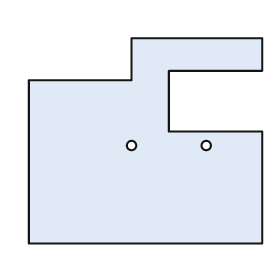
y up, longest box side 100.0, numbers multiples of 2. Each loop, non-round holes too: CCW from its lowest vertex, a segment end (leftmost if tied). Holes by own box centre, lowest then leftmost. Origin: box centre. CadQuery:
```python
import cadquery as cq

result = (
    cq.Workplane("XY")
    .moveTo(-50.0, -44.0)
    .lineTo(50.0, -44.0)
    .lineTo(50.0, 4.0)
    .lineTo(10.0, 4.0)
    .lineTo(10.0, 30.0)
    .lineTo(50.0, 30.0)
    .lineTo(50.0, 44.0)
    .lineTo(-6.0, 44.0)
    .lineTo(-6.0, 26.0)
    .lineTo(-50.0, 26.0)
    .close()
    .moveTo(-6.0, -2.0)
    .circle(2.0)
    .moveTo(26.0, -2.0)
    .circle(2.0)
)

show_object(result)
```